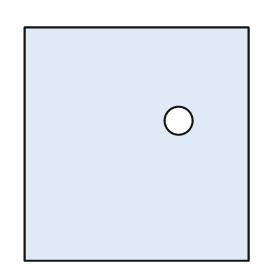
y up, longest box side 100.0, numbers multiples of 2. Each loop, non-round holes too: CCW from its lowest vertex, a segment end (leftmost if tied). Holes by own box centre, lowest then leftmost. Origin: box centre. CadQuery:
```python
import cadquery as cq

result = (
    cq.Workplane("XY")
    .moveTo(-48.0, -50.0)
    .lineTo(48.0, -50.0)
    .lineTo(48.0, 50.0)
    .lineTo(-48.0, 50.0)
    .close()
    .moveTo(18.0, 10.0)
    .circle(6.0)
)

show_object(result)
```